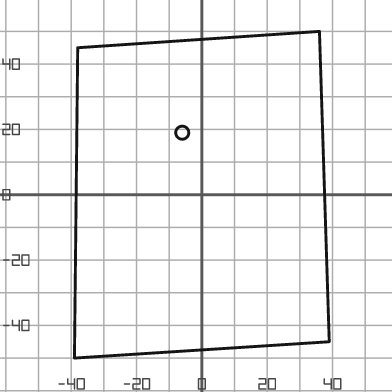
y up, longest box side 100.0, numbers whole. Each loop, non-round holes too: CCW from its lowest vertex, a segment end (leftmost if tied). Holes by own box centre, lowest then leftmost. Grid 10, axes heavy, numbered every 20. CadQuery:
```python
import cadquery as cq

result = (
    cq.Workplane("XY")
    .moveTo(-39.0, -50.0)
    .lineTo(39.0, -45.0)
    .lineTo(36.0, 50.0)
    .lineTo(-38.0, 45.0)
    .close()
    .moveTo(-6.0, 19.0)
    .circle(2.0)
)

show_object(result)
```